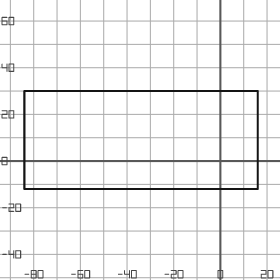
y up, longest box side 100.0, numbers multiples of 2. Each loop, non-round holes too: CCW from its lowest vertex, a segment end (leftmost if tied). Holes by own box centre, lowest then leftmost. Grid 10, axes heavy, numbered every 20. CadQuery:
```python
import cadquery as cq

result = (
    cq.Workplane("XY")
    .moveTo(-84.0, -12.0)
    .lineTo(16.0, -12.0)
    .lineTo(16.0, 30.0)
    .lineTo(-84.0, 30.0)
    .close()
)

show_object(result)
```